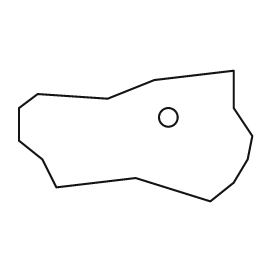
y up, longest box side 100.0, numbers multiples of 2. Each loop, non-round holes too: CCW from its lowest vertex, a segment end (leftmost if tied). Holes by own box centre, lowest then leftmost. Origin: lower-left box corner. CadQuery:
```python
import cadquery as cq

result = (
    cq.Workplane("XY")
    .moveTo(82.0, 0.0)
    .lineTo(92.0, 8.0)
    .lineTo(98.0, 18.0)
    .lineTo(100.0, 28.0)
    .lineTo(92.0, 40.0)
    .lineTo(92.0, 56.0)
    .lineTo(58.0, 52.0)
    .lineTo(38.0, 44.0)
    .lineTo(8.0, 46.0)
    .lineTo(0.0, 40.0)
    .lineTo(0.0, 26.0)
    .lineTo(10.0, 18.0)
    .lineTo(16.0, 6.0)
    .lineTo(50.0, 10.0)
    .close()
    .moveTo(64.0, 36.0)
    .circle(4.0)
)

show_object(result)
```